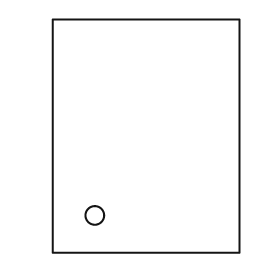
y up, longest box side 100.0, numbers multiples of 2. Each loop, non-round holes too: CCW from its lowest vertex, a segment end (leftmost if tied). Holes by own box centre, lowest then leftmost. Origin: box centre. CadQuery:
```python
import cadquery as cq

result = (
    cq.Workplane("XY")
    .moveTo(-40.0, -50.0)
    .lineTo(40.0, -50.0)
    .lineTo(40.0, 50.0)
    .lineTo(-40.0, 50.0)
    .close()
    .moveTo(-22.0, -34.0)
    .circle(4.0)
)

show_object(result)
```